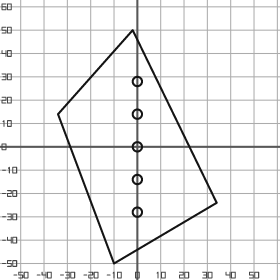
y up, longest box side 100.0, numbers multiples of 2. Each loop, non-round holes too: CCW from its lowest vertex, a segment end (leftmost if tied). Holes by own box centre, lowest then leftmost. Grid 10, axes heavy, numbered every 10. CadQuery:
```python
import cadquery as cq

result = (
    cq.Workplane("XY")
    .moveTo(-10.0, -50.0)
    .lineTo(34.0, -24.0)
    .lineTo(-2.0, 50.0)
    .lineTo(-34.0, 14.0)
    .close()
    .moveTo(0.0, -28.0)
    .circle(2.0)
    .moveTo(0.0, -14.0)
    .circle(2.0)
    .moveTo(0.0, 0.0)
    .circle(2.0)
    .moveTo(0.0, 14.0)
    .circle(2.0)
    .moveTo(0.0, 28.0)
    .circle(2.0)
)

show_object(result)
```